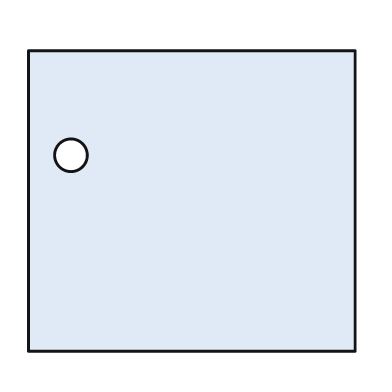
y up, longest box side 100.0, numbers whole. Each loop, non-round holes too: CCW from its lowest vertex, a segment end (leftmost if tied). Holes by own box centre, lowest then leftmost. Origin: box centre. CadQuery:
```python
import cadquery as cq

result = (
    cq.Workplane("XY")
    .moveTo(-50.0, -46.0)
    .lineTo(50.0, -46.0)
    .lineTo(50.0, 46.0)
    .lineTo(-50.0, 46.0)
    .close()
    .moveTo(-37.0, 14.0)
    .circle(5.0)
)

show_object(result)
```